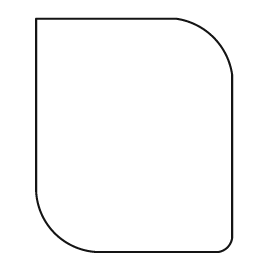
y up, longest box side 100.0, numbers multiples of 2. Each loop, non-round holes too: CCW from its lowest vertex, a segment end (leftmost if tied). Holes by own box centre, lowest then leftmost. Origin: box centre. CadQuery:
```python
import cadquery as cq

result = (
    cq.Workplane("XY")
    .moveTo(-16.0, -50.0)
    .lineTo(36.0, -50.0)
    .threePointArc((40.0, -48.0), (42.0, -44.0))
    .lineTo(42.0, 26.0)
    .threePointArc((34.0, 42.0), (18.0, 50.0))
    .lineTo(-42.0, 50.0)
    .lineTo(-42.0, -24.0)
    .threePointArc((-34.0, -42.0), (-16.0, -50.0))
    .close()
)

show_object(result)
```